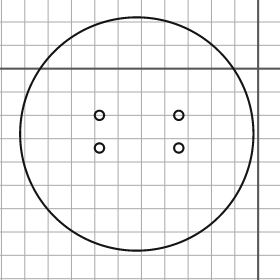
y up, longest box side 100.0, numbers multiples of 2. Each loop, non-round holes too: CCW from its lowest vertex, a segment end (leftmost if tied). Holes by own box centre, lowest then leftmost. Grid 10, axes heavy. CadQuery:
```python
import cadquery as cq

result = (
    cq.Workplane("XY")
    .moveTo(-52.0, -28.0)
    .circle(50.0)
    .moveTo(-68.0, -34.0)
    .circle(2.0)
    .moveTo(-34.0, -34.0)
    .circle(2.0)
    .moveTo(-68.0, -20.0)
    .circle(2.0)
    .moveTo(-34.0, -20.0)
    .circle(2.0)
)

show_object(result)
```